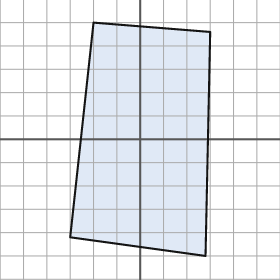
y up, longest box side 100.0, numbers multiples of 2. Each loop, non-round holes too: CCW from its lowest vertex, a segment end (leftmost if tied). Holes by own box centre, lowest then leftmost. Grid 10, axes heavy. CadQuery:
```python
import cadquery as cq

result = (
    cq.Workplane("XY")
    .moveTo(28.0, -50.0)
    .lineTo(30.0, 46.0)
    .lineTo(-20.0, 50.0)
    .lineTo(-30.0, -42.0)
    .close()
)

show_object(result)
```